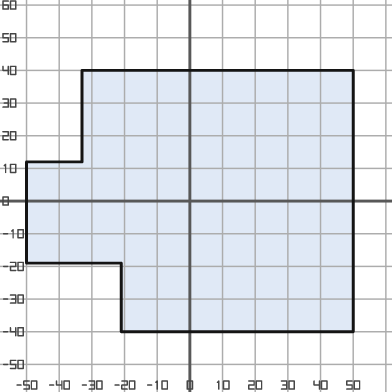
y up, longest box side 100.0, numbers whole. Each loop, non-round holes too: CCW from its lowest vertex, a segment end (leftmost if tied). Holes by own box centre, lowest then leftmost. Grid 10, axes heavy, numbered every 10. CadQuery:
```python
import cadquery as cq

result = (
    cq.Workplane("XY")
    .moveTo(-21.0, -40.0)
    .lineTo(50.0, -40.0)
    .lineTo(50.0, 40.0)
    .lineTo(-33.0, 40.0)
    .lineTo(-33.0, 12.0)
    .lineTo(-50.0, 12.0)
    .lineTo(-50.0, -19.0)
    .lineTo(-21.0, -19.0)
    .close()
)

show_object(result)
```